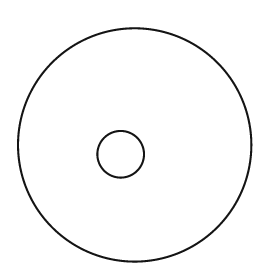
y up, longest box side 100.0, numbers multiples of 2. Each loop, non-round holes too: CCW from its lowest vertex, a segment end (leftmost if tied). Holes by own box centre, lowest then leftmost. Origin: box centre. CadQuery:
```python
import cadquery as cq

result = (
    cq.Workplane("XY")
    .moveTo(0.0, 0.0)
    .circle(50.0)
    .moveTo(-6.0, -4.0)
    .circle(10.0)
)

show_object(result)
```